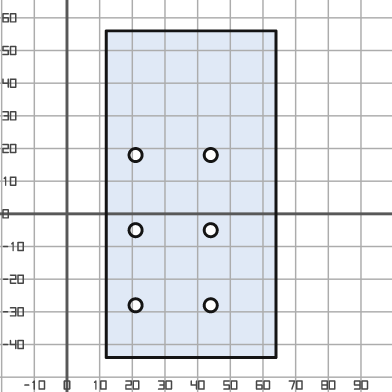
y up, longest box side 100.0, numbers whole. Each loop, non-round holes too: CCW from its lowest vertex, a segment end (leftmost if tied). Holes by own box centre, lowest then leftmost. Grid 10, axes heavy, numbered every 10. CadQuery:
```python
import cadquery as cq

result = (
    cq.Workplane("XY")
    .moveTo(12.0, -44.0)
    .lineTo(64.0, -44.0)
    .lineTo(64.0, 56.0)
    .lineTo(12.0, 56.0)
    .close()
    .moveTo(21.0, -28.0)
    .circle(2.0)
    .moveTo(44.0, -28.0)
    .circle(2.0)
    .moveTo(21.0, -5.0)
    .circle(2.0)
    .moveTo(44.0, -5.0)
    .circle(2.0)
    .moveTo(21.0, 18.0)
    .circle(2.0)
    .moveTo(44.0, 18.0)
    .circle(2.0)
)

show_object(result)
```